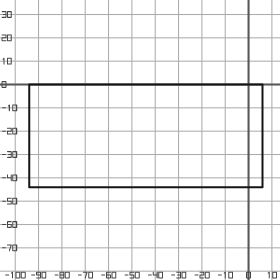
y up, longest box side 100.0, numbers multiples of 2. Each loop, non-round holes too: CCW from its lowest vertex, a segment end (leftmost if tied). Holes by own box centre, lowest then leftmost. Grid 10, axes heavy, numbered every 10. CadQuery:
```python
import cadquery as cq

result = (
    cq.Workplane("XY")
    .moveTo(-94.0, -44.0)
    .lineTo(6.0, -44.0)
    .lineTo(6.0, 0.0)
    .lineTo(-94.0, 0.0)
    .close()
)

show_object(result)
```